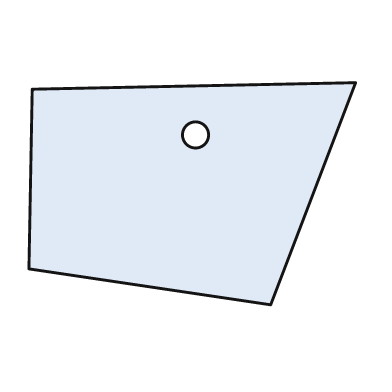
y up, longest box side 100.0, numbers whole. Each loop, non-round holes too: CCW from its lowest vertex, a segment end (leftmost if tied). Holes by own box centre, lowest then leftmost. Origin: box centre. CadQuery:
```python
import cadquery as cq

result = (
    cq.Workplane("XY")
    .moveTo(24.0, -34.0)
    .lineTo(50.0, 34.0)
    .lineTo(-49.0, 32.0)
    .lineTo(-50.0, -23.0)
    .close()
    .moveTo(1.0, 18.0)
    .circle(4.0)
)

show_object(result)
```